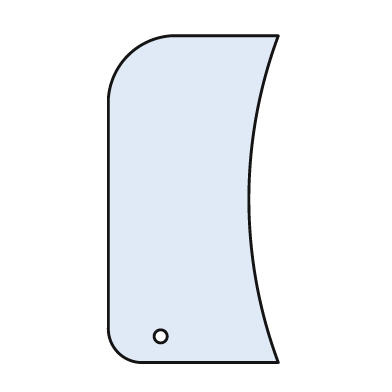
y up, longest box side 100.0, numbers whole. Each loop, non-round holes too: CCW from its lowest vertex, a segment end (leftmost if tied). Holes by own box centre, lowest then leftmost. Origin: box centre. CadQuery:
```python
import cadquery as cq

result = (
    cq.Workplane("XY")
    .moveTo(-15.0, -50.0)
    .lineTo(26.0, -50.0)
    .threePointArc((17.0, 0.0), (26.0, 50.0))
    .lineTo(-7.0, 50.0)
    .threePointArc((-20.0, 44.0), (-26.0, 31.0))
    .lineTo(-26.0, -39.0)
    .threePointArc((-23.0, -47.0), (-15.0, -50.0))
    .close()
    .moveTo(-10.0, -42.0)
    .circle(2.0)
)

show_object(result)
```